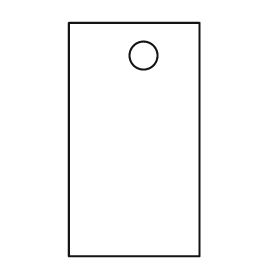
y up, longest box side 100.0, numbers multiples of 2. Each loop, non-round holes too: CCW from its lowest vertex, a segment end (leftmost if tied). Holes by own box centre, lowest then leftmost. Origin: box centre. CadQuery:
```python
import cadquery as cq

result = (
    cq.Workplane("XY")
    .moveTo(-28.0, -50.0)
    .lineTo(28.0, -50.0)
    .lineTo(28.0, 50.0)
    .lineTo(-28.0, 50.0)
    .close()
    .moveTo(4.0, 36.0)
    .circle(6.0)
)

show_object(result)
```